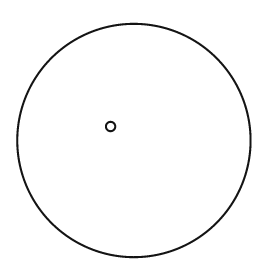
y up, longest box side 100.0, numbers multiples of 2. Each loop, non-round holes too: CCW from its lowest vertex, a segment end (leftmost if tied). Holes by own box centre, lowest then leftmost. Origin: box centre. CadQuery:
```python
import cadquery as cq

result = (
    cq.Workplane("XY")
    .moveTo(0.0, 0.0)
    .circle(50.0)
    .moveTo(-10.0, 6.0)
    .circle(2.0)
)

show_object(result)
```